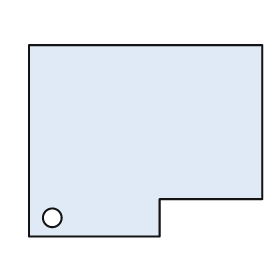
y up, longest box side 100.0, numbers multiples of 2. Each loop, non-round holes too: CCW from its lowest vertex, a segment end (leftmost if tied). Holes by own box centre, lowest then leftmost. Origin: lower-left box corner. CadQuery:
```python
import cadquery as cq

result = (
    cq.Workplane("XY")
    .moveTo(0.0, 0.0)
    .lineTo(56.0, 0.0)
    .lineTo(56.0, 16.0)
    .lineTo(100.0, 16.0)
    .lineTo(100.0, 82.0)
    .lineTo(0.0, 82.0)
    .close()
    .moveTo(10.0, 8.0)
    .circle(4.0)
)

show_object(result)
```